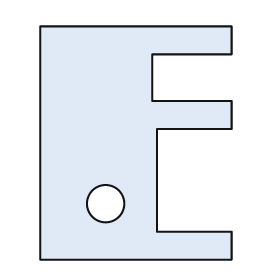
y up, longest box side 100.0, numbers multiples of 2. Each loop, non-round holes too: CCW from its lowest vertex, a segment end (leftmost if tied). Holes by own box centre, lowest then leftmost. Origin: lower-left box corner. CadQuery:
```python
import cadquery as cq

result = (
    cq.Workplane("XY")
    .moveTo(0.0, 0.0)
    .lineTo(82.0, 0.0)
    .lineTo(82.0, 12.0)
    .lineTo(50.0, 12.0)
    .lineTo(50.0, 56.0)
    .lineTo(82.0, 56.0)
    .lineTo(82.0, 68.0)
    .lineTo(48.0, 68.0)
    .lineTo(48.0, 88.0)
    .lineTo(82.0, 88.0)
    .lineTo(82.0, 100.0)
    .lineTo(0.0, 100.0)
    .close()
    .moveTo(28.0, 24.0)
    .circle(8.0)
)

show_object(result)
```